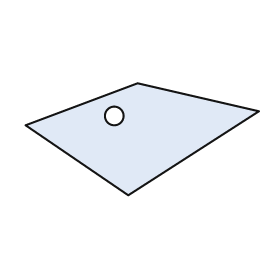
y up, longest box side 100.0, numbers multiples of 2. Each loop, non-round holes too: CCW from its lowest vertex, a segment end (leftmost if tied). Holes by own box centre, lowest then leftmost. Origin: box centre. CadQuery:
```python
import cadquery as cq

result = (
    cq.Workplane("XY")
    .moveTo(-6.0, -24.0)
    .lineTo(50.0, 12.0)
    .lineTo(-2.0, 24.0)
    .lineTo(-50.0, 6.0)
    .close()
    .moveTo(-12.0, 10.0)
    .circle(4.0)
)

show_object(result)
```